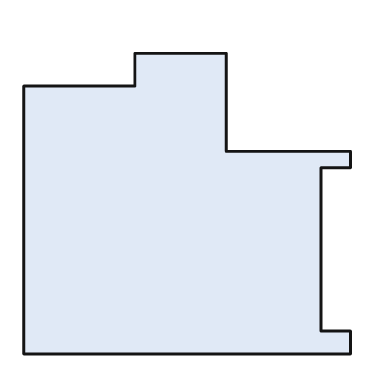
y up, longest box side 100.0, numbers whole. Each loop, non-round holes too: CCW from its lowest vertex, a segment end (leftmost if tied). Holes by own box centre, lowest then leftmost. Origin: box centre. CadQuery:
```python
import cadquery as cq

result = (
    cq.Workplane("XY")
    .moveTo(-50.0, -46.0)
    .lineTo(50.0, -46.0)
    .lineTo(50.0, -39.0)
    .lineTo(41.0, -39.0)
    .lineTo(41.0, 11.0)
    .lineTo(50.0, 11.0)
    .lineTo(50.0, 16.0)
    .lineTo(12.0, 16.0)
    .lineTo(12.0, 46.0)
    .lineTo(-16.0, 46.0)
    .lineTo(-16.0, 36.0)
    .lineTo(-50.0, 36.0)
    .close()
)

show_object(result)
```